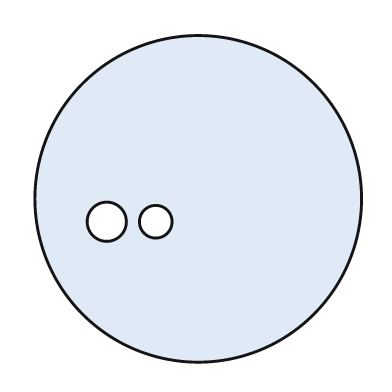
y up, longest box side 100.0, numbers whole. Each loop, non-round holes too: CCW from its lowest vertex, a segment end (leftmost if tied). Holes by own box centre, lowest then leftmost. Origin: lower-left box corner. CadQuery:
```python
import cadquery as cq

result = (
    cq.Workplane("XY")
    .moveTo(50.0, 50.0)
    .circle(50.0)
    .moveTo(22.0, 43.0)
    .circle(6.0)
    .moveTo(37.0, 43.0)
    .circle(5.0)
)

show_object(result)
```